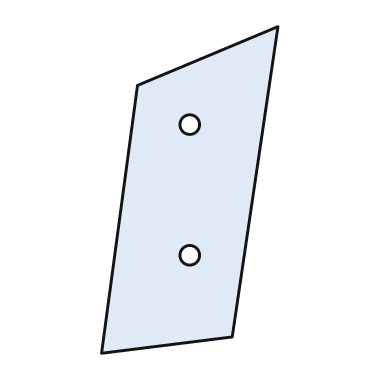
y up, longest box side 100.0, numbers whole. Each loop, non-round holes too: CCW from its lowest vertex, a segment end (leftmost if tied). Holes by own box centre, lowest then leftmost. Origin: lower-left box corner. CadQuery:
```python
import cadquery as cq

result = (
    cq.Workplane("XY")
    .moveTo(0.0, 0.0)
    .lineTo(40.0, 5.0)
    .lineTo(54.0, 100.0)
    .lineTo(11.0, 82.0)
    .close()
    .moveTo(27.0, 30.0)
    .circle(3.0)
    .moveTo(27.0, 70.0)
    .circle(3.0)
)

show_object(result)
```